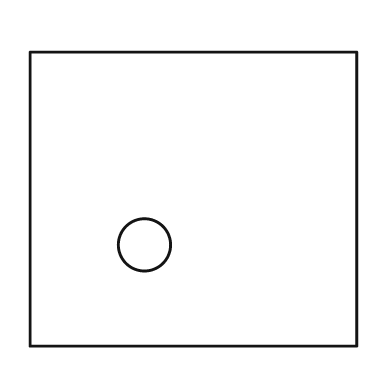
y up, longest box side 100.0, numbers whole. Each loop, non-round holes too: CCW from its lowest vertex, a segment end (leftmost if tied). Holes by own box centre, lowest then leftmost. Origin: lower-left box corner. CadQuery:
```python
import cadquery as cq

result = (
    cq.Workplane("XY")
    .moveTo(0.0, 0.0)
    .lineTo(100.0, 0.0)
    .lineTo(100.0, 90.0)
    .lineTo(0.0, 90.0)
    .close()
    .moveTo(35.0, 31.0)
    .circle(8.0)
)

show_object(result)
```